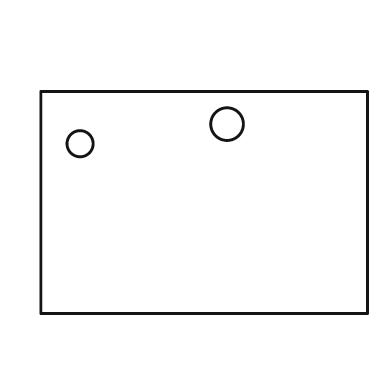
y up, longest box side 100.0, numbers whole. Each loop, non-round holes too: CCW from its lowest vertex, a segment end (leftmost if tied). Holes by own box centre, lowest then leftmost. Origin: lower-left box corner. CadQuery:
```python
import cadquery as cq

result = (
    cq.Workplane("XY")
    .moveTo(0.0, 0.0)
    .lineTo(100.0, 0.0)
    .lineTo(100.0, 68.0)
    .lineTo(0.0, 68.0)
    .close()
    .moveTo(12.0, 52.0)
    .circle(4.0)
    .moveTo(57.0, 58.0)
    .circle(5.0)
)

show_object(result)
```